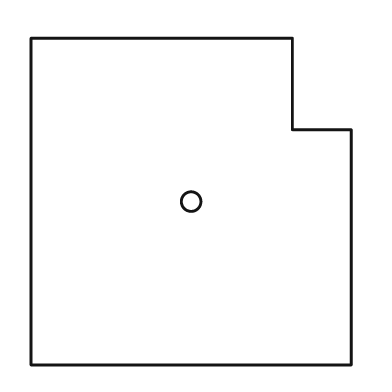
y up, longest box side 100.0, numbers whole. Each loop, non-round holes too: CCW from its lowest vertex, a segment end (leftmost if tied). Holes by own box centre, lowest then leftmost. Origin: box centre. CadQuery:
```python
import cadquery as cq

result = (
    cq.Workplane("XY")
    .moveTo(-49.0, -50.0)
    .lineTo(49.0, -50.0)
    .lineTo(49.0, 22.0)
    .lineTo(31.0, 22.0)
    .lineTo(31.0, 50.0)
    .lineTo(-49.0, 50.0)
    .close()
    .moveTo(0.0, 0.0)
    .circle(3.0)
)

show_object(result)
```